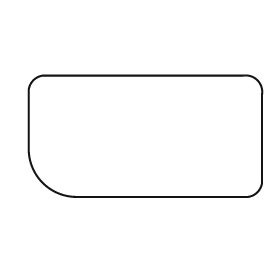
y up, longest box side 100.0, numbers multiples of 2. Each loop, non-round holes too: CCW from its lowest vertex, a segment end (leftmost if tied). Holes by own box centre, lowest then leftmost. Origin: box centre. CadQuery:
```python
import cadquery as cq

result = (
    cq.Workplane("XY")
    .moveTo(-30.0, -26.0)
    .lineTo(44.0, -26.0)
    .threePointArc((48.0, -24.0), (50.0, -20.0))
    .lineTo(50.0, 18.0)
    .threePointArc((48.0, 24.0), (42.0, 26.0))
    .lineTo(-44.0, 26.0)
    .threePointArc((-48.0, 24.0), (-50.0, 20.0))
    .lineTo(-50.0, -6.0)
    .threePointArc((-44.0, -20.0), (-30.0, -26.0))
    .close()
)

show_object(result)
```